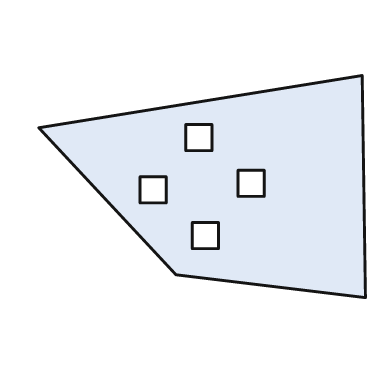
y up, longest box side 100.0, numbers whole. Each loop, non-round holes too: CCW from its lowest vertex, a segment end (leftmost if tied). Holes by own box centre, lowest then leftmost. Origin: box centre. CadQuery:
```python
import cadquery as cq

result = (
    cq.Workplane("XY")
    .moveTo(50.0, -34.0)
    .lineTo(49.0, 34.0)
    .lineTo(-50.0, 18.0)
    .lineTo(-8.0, -27.0)
    .close()
    .moveTo(-3.0, -19.0)
    .lineTo(5.0, -19.0)
    .lineTo(5.0, -11.0)
    .lineTo(-3.0, -11.0)
    .close()
    .moveTo(-19.0, -5.0)
    .lineTo(-11.0, -5.0)
    .lineTo(-11.0, 3.0)
    .lineTo(-19.0, 3.0)
    .close()
    .moveTo(11.0, -3.0)
    .lineTo(19.0, -3.0)
    .lineTo(19.0, 5.0)
    .lineTo(11.0, 5.0)
    .close()
    .moveTo(-5.0, 11.0)
    .lineTo(3.0, 11.0)
    .lineTo(3.0, 19.0)
    .lineTo(-5.0, 19.0)
    .close()
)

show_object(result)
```